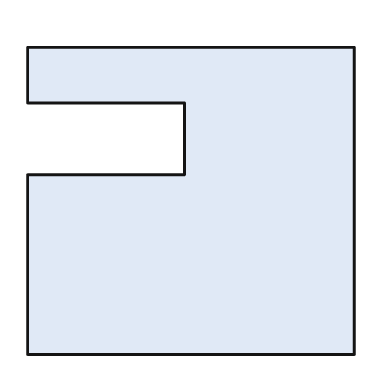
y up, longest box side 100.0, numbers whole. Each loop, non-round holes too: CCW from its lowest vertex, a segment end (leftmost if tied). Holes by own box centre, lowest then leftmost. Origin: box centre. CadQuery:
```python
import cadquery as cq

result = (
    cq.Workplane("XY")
    .moveTo(-50.0, -47.0)
    .lineTo(50.0, -47.0)
    .lineTo(50.0, 47.0)
    .lineTo(-50.0, 47.0)
    .lineTo(-50.0, 30.0)
    .lineTo(-2.0, 30.0)
    .lineTo(-2.0, 8.0)
    .lineTo(-50.0, 8.0)
    .close()
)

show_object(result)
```